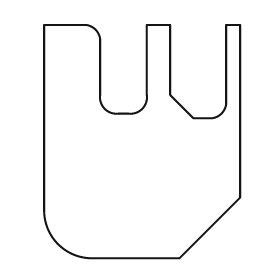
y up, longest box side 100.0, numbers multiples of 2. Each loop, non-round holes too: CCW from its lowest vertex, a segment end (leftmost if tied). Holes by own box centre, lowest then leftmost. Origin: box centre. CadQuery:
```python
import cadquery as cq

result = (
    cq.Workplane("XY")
    .moveTo(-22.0, -50.0)
    .lineTo(16.0, -50.0)
    .lineTo(42.0, -24.0)
    .lineTo(42.0, 50.0)
    .lineTo(36.0, 50.0)
    .lineTo(36.0, 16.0)
    .threePointArc((34.0, 12.0), (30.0, 10.0))
    .lineTo(22.0, 10.0)
    .lineTo(12.0, 20.0)
    .lineTo(12.0, 50.0)
    .lineTo(2.0, 50.0)
    .lineTo(2.0, 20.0)
    .threePointArc((0.0, 14.0), (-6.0, 12.0))
    .lineTo(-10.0, 12.0)
    .threePointArc((-16.0, 14.0), (-18.0, 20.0))
    .lineTo(-18.0, 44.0)
    .threePointArc((-20.0, 48.0), (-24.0, 50.0))
    .lineTo(-42.0, 50.0)
    .lineTo(-42.0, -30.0)
    .threePointArc((-36.0, -44.0), (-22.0, -50.0))
    .close()
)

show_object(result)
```